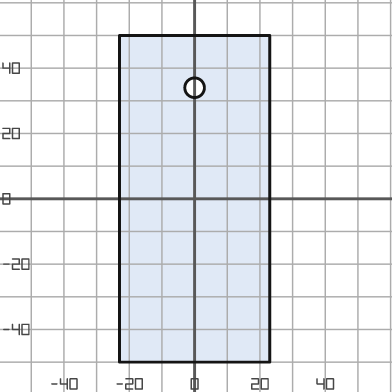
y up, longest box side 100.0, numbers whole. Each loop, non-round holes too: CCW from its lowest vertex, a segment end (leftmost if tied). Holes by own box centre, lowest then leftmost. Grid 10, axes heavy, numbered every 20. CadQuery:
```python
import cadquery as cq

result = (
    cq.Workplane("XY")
    .moveTo(-23.0, -50.0)
    .lineTo(23.0, -50.0)
    .lineTo(23.0, 50.0)
    .lineTo(-23.0, 50.0)
    .close()
    .moveTo(0.0, 34.0)
    .circle(3.0)
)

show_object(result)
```